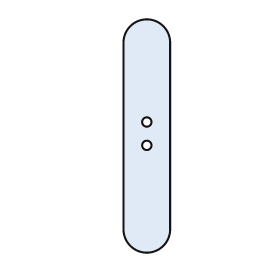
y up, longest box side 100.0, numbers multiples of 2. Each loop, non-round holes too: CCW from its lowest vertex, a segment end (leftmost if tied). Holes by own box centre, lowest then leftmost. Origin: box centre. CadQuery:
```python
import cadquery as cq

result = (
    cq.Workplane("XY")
    .moveTo(-10.0, -40.0)
    .threePointArc((0.0, -50.0), (10.0, -40.0))
    .lineTo(10.0, 40.0)
    .threePointArc((0.0, 50.0), (-10.0, 40.0))
    .close()
    .moveTo(0.0, -4.0)
    .circle(2.0)
    .moveTo(0.0, 6.0)
    .circle(2.0)
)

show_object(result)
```